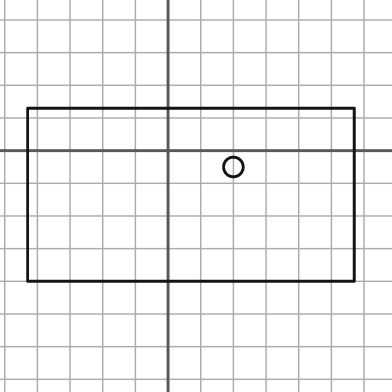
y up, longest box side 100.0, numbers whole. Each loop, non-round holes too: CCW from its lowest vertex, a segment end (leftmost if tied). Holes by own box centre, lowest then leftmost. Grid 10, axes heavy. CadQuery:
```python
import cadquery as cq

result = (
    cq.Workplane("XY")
    .moveTo(-43.0, -40.0)
    .lineTo(57.0, -40.0)
    .lineTo(57.0, 13.0)
    .lineTo(-43.0, 13.0)
    .close()
    .moveTo(20.0, -5.0)
    .circle(3.0)
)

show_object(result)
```